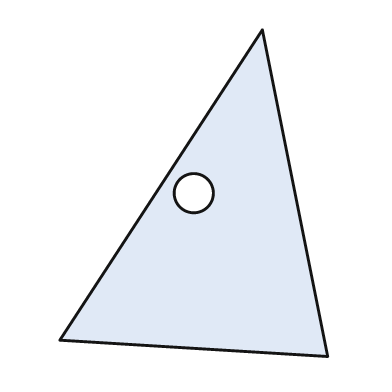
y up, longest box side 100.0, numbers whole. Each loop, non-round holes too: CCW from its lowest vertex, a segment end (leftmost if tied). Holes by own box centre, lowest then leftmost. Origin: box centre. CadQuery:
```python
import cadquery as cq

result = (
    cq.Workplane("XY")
    .moveTo(41.0, -50.0)
    .lineTo(21.0, 50.0)
    .lineTo(-41.0, -45.0)
    .close()
    .moveTo(0.0, 0.0)
    .circle(6.0)
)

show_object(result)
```